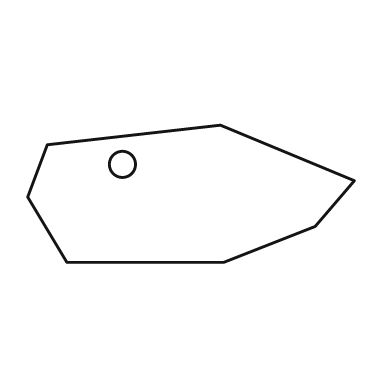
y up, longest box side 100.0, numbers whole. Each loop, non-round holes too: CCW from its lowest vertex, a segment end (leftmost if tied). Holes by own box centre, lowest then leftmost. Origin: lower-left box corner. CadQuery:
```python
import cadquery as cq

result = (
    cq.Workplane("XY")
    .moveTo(12.0, 0.0)
    .lineTo(60.0, 0.0)
    .lineTo(88.0, 11.0)
    .lineTo(100.0, 25.0)
    .lineTo(59.0, 42.0)
    .lineTo(6.0, 36.0)
    .lineTo(0.0, 20.0)
    .close()
    .moveTo(29.0, 30.0)
    .circle(4.0)
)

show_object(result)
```